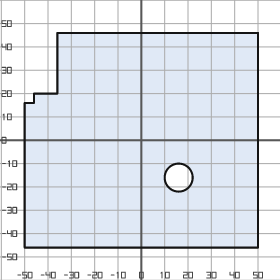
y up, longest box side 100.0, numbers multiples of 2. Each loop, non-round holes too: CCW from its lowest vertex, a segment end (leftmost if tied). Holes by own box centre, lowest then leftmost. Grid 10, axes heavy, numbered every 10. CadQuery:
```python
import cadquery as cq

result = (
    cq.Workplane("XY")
    .moveTo(-50.0, -46.0)
    .lineTo(50.0, -46.0)
    .lineTo(50.0, 46.0)
    .lineTo(-36.0, 46.0)
    .lineTo(-36.0, 20.0)
    .lineTo(-46.0, 20.0)
    .lineTo(-46.0, 16.0)
    .lineTo(-50.0, 16.0)
    .close()
    .moveTo(16.0, -16.0)
    .circle(6.0)
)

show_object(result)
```